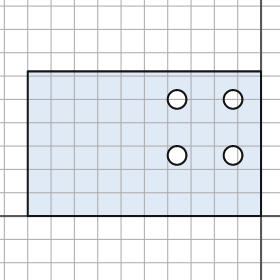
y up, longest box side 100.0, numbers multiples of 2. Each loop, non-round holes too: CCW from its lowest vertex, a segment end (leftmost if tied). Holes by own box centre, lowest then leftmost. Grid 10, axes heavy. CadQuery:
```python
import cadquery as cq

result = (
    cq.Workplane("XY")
    .moveTo(-100.0, 0.0)
    .lineTo(0.0, 0.0)
    .lineTo(0.0, 62.0)
    .lineTo(-100.0, 62.0)
    .close()
    .moveTo(-36.0, 26.0)
    .circle(4.0)
    .moveTo(-12.0, 26.0)
    .circle(4.0)
    .moveTo(-36.0, 50.0)
    .circle(4.0)
    .moveTo(-12.0, 50.0)
    .circle(4.0)
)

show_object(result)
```